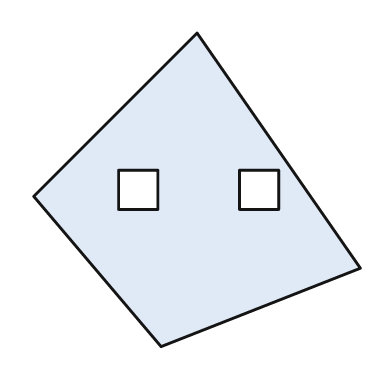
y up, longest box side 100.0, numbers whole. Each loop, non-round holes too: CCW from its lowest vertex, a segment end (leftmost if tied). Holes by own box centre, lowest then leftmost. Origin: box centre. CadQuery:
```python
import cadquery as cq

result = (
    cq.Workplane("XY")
    .moveTo(-11.0, -48.0)
    .lineTo(50.0, -24.0)
    .lineTo(0.0, 48.0)
    .lineTo(-50.0, -2.0)
    .close()
    .moveTo(-24.0, -6.0)
    .lineTo(-12.0, -6.0)
    .lineTo(-12.0, 6.0)
    .lineTo(-24.0, 6.0)
    .close()
    .moveTo(13.0, -6.0)
    .lineTo(25.0, -6.0)
    .lineTo(25.0, 6.0)
    .lineTo(13.0, 6.0)
    .close()
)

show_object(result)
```